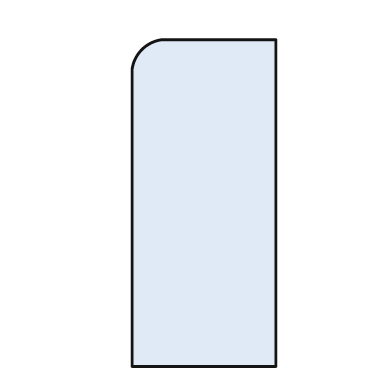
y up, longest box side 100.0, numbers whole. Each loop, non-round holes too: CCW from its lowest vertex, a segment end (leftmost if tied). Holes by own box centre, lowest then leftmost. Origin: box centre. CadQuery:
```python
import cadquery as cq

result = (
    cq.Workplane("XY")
    .moveTo(-22.0, -50.0)
    .lineTo(22.0, -50.0)
    .lineTo(22.0, 50.0)
    .lineTo(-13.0, 50.0)
    .threePointArc((-19.0, 47.0), (-22.0, 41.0))
    .close()
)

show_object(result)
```